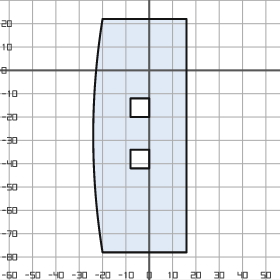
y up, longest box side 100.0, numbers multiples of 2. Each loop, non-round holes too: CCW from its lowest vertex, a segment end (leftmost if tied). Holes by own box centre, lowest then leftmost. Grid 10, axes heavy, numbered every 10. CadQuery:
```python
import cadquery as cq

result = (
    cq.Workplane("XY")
    .moveTo(-20.0, -78.0)
    .lineTo(16.0, -78.0)
    .lineTo(16.0, 22.0)
    .lineTo(-20.0, 22.0)
    .threePointArc((-24.0, -28.0), (-20.0, -78.0))
    .close()
    .moveTo(-8.0, -42.0)
    .lineTo(0.0, -42.0)
    .lineTo(0.0, -34.0)
    .lineTo(-8.0, -34.0)
    .close()
    .moveTo(-8.0, -20.0)
    .lineTo(0.0, -20.0)
    .lineTo(0.0, -12.0)
    .lineTo(-8.0, -12.0)
    .close()
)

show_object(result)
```